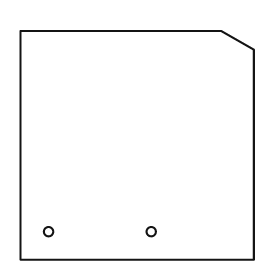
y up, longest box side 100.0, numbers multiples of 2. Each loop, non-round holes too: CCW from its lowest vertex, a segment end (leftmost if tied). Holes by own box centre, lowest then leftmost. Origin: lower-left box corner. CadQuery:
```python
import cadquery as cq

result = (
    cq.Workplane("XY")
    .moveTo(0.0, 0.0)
    .lineTo(100.0, 0.0)
    .lineTo(100.0, 90.0)
    .lineTo(86.0, 98.0)
    .lineTo(0.0, 98.0)
    .close()
    .moveTo(12.0, 12.0)
    .circle(2.0)
    .moveTo(56.0, 12.0)
    .circle(2.0)
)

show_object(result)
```